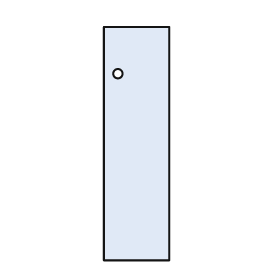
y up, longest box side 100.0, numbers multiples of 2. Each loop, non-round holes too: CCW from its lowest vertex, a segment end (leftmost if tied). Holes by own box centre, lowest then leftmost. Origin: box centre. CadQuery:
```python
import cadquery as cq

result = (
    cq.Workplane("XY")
    .moveTo(-14.0, -50.0)
    .lineTo(14.0, -50.0)
    .lineTo(14.0, 50.0)
    .lineTo(-14.0, 50.0)
    .close()
    .moveTo(-8.0, 30.0)
    .circle(2.0)
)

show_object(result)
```